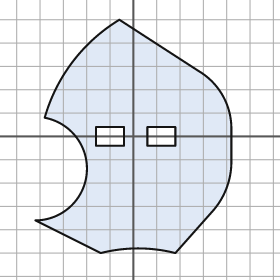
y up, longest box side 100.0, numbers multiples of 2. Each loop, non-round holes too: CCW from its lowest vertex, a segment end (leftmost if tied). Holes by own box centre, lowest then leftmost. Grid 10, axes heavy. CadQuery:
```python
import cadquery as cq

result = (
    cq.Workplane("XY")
    .moveTo(-14.0, -50.0)
    .threePointArc((2.0, -48.0), (18.0, -50.0))
    .lineTo(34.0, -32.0)
    .threePointArc((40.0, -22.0), (42.0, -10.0))
    .lineTo(42.0, 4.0)
    .threePointArc((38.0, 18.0), (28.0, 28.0))
    .lineTo(-6.0, 50.0)
    .threePointArc((-26.0, 32.0), (-38.0, 8.0))
    .threePointArc((-20.0, -16.0), (-42.0, -36.0))
    .close()
    .moveTo(-16.0, -4.0)
    .lineTo(-4.0, -4.0)
    .lineTo(-4.0, 4.0)
    .lineTo(-16.0, 4.0)
    .close()
    .moveTo(6.0, -4.0)
    .lineTo(18.0, -4.0)
    .lineTo(18.0, 4.0)
    .lineTo(6.0, 4.0)
    .close()
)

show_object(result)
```